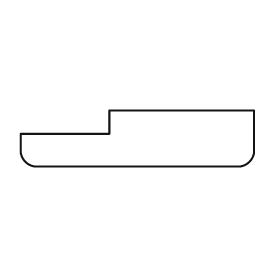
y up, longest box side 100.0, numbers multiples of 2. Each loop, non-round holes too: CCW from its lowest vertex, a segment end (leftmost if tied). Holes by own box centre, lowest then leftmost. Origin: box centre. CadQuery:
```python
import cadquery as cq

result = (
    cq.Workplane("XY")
    .moveTo(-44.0, -12.0)
    .lineTo(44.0, -12.0)
    .threePointArc((48.0, -10.0), (50.0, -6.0))
    .lineTo(50.0, 12.0)
    .lineTo(-12.0, 12.0)
    .lineTo(-12.0, 2.0)
    .lineTo(-50.0, 2.0)
    .lineTo(-50.0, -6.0)
    .threePointArc((-48.0, -10.0), (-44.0, -12.0))
    .close()
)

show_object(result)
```